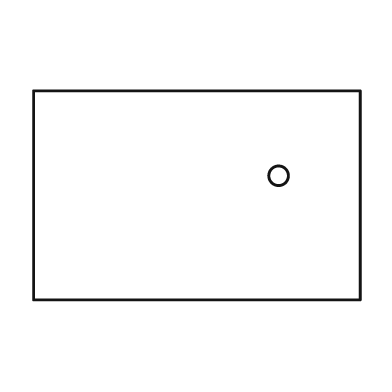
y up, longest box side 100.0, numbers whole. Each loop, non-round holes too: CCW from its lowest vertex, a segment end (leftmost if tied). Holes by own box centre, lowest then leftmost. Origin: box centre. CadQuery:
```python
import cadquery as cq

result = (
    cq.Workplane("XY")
    .moveTo(-50.0, -32.0)
    .lineTo(50.0, -32.0)
    .lineTo(50.0, 32.0)
    .lineTo(-50.0, 32.0)
    .close()
    .moveTo(25.0, 6.0)
    .circle(3.0)
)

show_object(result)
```